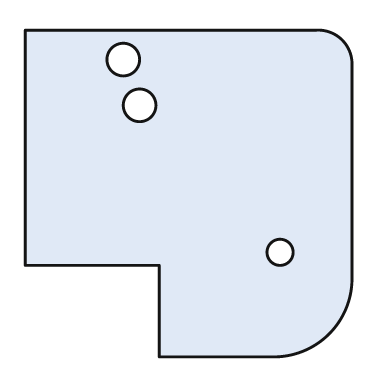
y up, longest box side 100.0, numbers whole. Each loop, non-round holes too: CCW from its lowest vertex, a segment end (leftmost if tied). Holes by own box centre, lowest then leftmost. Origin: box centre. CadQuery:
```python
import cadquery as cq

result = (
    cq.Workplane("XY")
    .moveTo(-9.0, -50.0)
    .lineTo(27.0, -50.0)
    .threePointArc((43.0, -43.0), (50.0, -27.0))
    .lineTo(50.0, 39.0)
    .threePointArc((47.0, 47.0), (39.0, 50.0))
    .lineTo(-50.0, 50.0)
    .lineTo(-50.0, -22.0)
    .lineTo(-9.0, -22.0)
    .close()
    .moveTo(28.0, -18.0)
    .circle(4.0)
    .moveTo(-15.0, 27.0)
    .circle(5.0)
    .moveTo(-20.0, 41.0)
    .circle(5.0)
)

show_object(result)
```